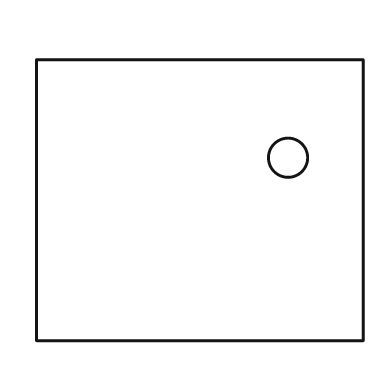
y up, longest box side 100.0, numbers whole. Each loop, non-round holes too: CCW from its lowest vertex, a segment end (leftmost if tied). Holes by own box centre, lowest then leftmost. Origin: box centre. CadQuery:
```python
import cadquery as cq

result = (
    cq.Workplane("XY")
    .moveTo(-50.0, -43.0)
    .lineTo(50.0, -43.0)
    .lineTo(50.0, 43.0)
    .lineTo(-50.0, 43.0)
    .close()
    .moveTo(27.0, 13.0)
    .circle(6.0)
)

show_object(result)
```